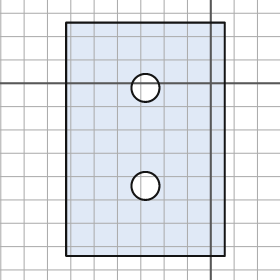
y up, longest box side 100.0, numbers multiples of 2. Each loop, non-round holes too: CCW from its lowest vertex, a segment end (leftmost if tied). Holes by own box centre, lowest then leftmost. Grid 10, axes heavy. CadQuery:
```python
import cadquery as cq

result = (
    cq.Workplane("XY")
    .moveTo(-62.0, -74.0)
    .lineTo(6.0, -74.0)
    .lineTo(6.0, 26.0)
    .lineTo(-62.0, 26.0)
    .close()
    .moveTo(-28.0, -44.0)
    .circle(6.0)
    .moveTo(-28.0, -2.0)
    .circle(6.0)
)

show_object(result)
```